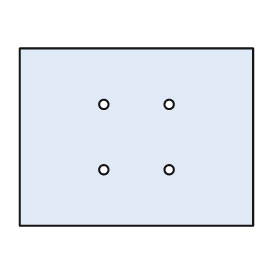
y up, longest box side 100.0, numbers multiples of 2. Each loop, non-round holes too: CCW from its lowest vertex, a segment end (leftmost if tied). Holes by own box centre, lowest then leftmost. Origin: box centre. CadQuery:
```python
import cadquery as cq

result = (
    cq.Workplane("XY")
    .moveTo(-50.0, -38.0)
    .lineTo(50.0, -38.0)
    .lineTo(50.0, 38.0)
    .lineTo(-50.0, 38.0)
    .close()
    .moveTo(-14.0, -14.0)
    .circle(2.0)
    .moveTo(14.0, -14.0)
    .circle(2.0)
    .moveTo(-14.0, 14.0)
    .circle(2.0)
    .moveTo(14.0, 14.0)
    .circle(2.0)
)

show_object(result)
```